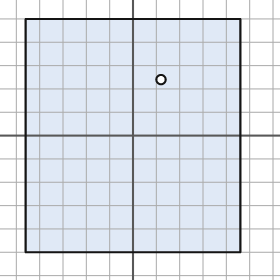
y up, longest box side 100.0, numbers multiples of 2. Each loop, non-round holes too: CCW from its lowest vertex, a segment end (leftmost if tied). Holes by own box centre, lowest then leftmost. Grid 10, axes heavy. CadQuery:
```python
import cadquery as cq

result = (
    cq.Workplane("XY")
    .moveTo(-46.0, -50.0)
    .lineTo(46.0, -50.0)
    .lineTo(46.0, 50.0)
    .lineTo(-46.0, 50.0)
    .close()
    .moveTo(12.0, 24.0)
    .circle(2.0)
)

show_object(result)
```